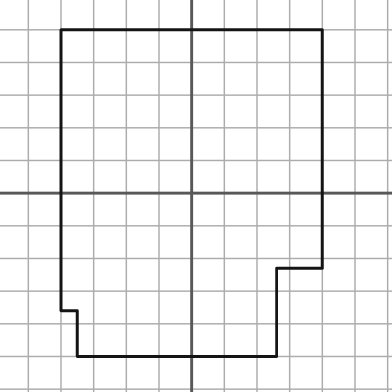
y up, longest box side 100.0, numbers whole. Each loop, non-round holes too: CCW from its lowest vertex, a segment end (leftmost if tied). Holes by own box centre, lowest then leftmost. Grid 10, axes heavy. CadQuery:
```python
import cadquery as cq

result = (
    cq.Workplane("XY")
    .moveTo(-35.0, -50.0)
    .lineTo(26.0, -50.0)
    .lineTo(26.0, -23.0)
    .lineTo(40.0, -23.0)
    .lineTo(40.0, 50.0)
    .lineTo(-40.0, 50.0)
    .lineTo(-40.0, -36.0)
    .lineTo(-35.0, -36.0)
    .close()
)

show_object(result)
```